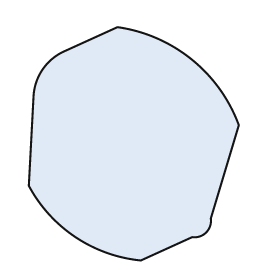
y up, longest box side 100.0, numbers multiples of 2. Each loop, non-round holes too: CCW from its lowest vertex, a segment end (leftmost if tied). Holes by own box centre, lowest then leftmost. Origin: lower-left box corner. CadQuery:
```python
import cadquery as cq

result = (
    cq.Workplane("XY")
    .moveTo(48.0, 0.0)
    .lineTo(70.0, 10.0)
    .threePointArc((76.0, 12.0), (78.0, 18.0))
    .lineTo(90.0, 58.0)
    .threePointArc((70.0, 86.0), (38.0, 100.0))
    .lineTo(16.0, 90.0)
    .threePointArc((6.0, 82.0), (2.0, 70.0))
    .lineTo(0.0, 32.0)
    .threePointArc((20.0, 10.0), (48.0, 0.0))
    .close()
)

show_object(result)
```